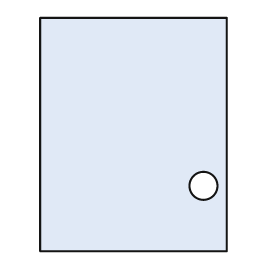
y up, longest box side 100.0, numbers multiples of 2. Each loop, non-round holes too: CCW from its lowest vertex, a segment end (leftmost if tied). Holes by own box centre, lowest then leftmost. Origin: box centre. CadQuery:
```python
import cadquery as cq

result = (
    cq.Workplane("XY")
    .moveTo(-40.0, -50.0)
    .lineTo(40.0, -50.0)
    .lineTo(40.0, 50.0)
    .lineTo(-40.0, 50.0)
    .close()
    .moveTo(30.0, -22.0)
    .circle(6.0)
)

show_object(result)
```